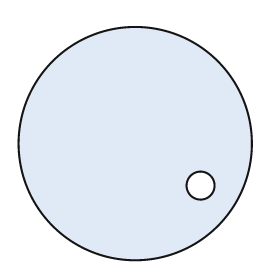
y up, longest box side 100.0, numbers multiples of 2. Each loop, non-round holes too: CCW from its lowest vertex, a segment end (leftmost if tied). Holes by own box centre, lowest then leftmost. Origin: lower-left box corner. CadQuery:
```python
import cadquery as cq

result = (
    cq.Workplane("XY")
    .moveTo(50.0, 50.0)
    .circle(50.0)
    .moveTo(78.0, 32.0)
    .circle(6.0)
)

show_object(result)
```